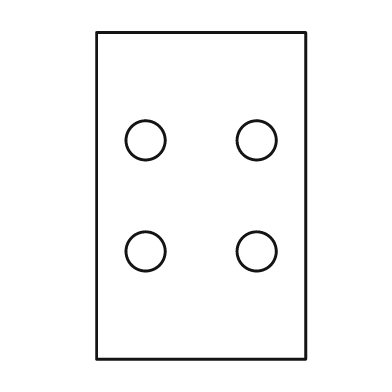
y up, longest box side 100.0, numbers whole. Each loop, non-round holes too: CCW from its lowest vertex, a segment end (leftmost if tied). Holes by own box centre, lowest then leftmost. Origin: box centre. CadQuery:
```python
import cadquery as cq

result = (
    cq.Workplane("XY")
    .moveTo(-32.0, -50.0)
    .lineTo(32.0, -50.0)
    .lineTo(32.0, 50.0)
    .lineTo(-32.0, 50.0)
    .close()
    .moveTo(-17.0, -17.0)
    .circle(6.0)
    .moveTo(17.0, -17.0)
    .circle(6.0)
    .moveTo(-17.0, 17.0)
    .circle(6.0)
    .moveTo(17.0, 17.0)
    .circle(6.0)
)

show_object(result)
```